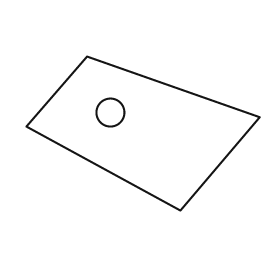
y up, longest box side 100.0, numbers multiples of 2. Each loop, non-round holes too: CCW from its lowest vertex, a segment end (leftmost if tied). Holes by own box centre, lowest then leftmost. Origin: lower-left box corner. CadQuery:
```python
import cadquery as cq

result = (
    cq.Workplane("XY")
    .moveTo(66.0, 0.0)
    .lineTo(100.0, 40.0)
    .lineTo(26.0, 66.0)
    .lineTo(0.0, 36.0)
    .close()
    .moveTo(36.0, 42.0)
    .circle(6.0)
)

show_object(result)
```